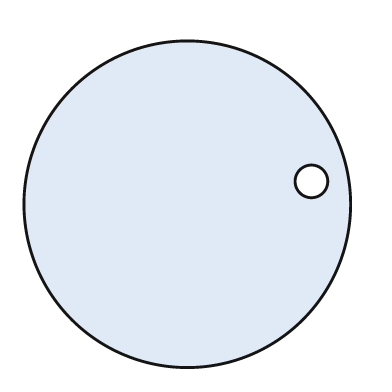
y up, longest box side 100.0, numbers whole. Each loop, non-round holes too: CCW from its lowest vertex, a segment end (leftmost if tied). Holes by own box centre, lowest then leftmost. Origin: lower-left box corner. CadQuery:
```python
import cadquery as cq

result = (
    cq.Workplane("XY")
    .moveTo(50.0, 50.0)
    .circle(50.0)
    .moveTo(88.0, 57.0)
    .circle(5.0)
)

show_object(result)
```